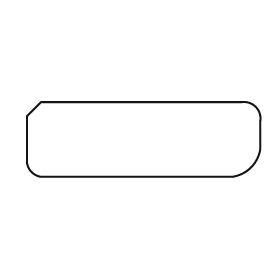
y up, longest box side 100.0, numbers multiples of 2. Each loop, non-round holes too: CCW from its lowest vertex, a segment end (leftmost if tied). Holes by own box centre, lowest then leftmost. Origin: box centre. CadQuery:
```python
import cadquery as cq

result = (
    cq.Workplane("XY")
    .moveTo(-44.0, -16.0)
    .lineTo(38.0, -16.0)
    .threePointArc((46.0, -12.0), (50.0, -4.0))
    .lineTo(50.0, 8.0)
    .threePointArc((48.0, 14.0), (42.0, 16.0))
    .lineTo(-44.0, 16.0)
    .lineTo(-50.0, 10.0)
    .lineTo(-50.0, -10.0)
    .threePointArc((-48.0, -14.0), (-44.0, -16.0))
    .close()
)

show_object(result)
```